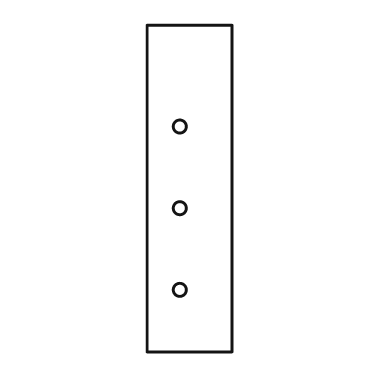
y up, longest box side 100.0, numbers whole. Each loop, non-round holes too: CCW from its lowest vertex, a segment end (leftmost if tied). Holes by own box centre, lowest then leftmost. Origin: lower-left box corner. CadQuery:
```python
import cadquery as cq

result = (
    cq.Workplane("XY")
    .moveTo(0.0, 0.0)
    .lineTo(26.0, 0.0)
    .lineTo(26.0, 100.0)
    .lineTo(0.0, 100.0)
    .close()
    .moveTo(10.0, 19.0)
    .circle(2.0)
    .moveTo(10.0, 44.0)
    .circle(2.0)
    .moveTo(10.0, 69.0)
    .circle(2.0)
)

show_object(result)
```